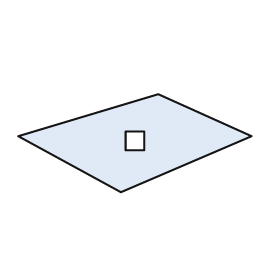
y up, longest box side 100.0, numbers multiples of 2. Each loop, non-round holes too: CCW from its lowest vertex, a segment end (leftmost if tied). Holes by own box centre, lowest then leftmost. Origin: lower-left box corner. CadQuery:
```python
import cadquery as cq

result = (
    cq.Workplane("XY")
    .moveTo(44.0, 0.0)
    .lineTo(100.0, 24.0)
    .lineTo(60.0, 42.0)
    .lineTo(0.0, 24.0)
    .close()
    .moveTo(46.0, 18.0)
    .lineTo(54.0, 18.0)
    .lineTo(54.0, 26.0)
    .lineTo(46.0, 26.0)
    .close()
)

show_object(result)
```